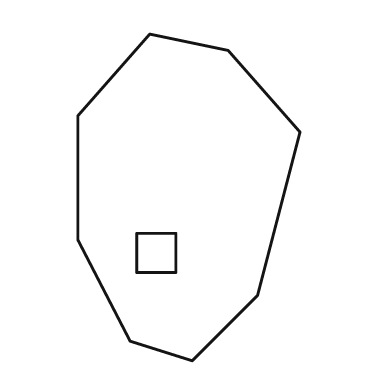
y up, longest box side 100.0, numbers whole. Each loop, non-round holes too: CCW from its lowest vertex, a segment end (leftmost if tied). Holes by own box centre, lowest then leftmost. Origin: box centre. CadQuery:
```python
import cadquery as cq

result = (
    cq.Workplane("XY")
    .moveTo(1.0, -50.0)
    .lineTo(21.0, -30.0)
    .lineTo(34.0, 20.0)
    .lineTo(12.0, 45.0)
    .lineTo(-12.0, 50.0)
    .lineTo(-34.0, 25.0)
    .lineTo(-34.0, -13.0)
    .lineTo(-18.0, -44.0)
    .close()
    .moveTo(-16.0, -23.0)
    .lineTo(-4.0, -23.0)
    .lineTo(-4.0, -11.0)
    .lineTo(-16.0, -11.0)
    .close()
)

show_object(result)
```